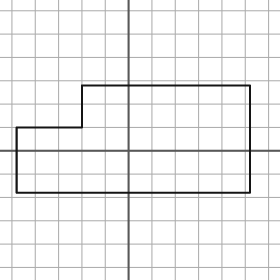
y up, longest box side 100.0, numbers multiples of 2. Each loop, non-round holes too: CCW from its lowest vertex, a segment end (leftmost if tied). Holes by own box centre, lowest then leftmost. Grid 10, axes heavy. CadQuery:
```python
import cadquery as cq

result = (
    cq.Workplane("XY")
    .moveTo(-48.0, -18.0)
    .lineTo(52.0, -18.0)
    .lineTo(52.0, 28.0)
    .lineTo(-20.0, 28.0)
    .lineTo(-20.0, 10.0)
    .lineTo(-48.0, 10.0)
    .close()
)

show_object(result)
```